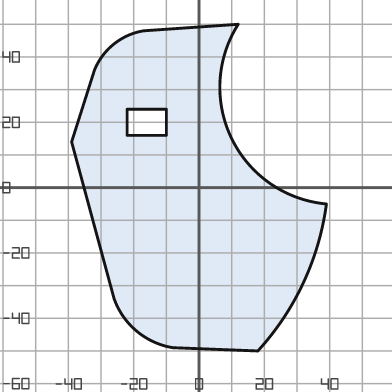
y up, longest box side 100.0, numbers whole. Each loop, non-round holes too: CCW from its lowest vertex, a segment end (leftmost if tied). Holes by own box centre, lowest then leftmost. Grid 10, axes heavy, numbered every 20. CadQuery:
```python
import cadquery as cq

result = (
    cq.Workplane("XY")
    .moveTo(18.0, -50.0)
    .threePointArc((32.0, -29.0), (39.0, -5.0))
    .threePointArc((10.0, 15.0), (12.0, 50.0))
    .lineTo(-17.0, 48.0)
    .threePointArc((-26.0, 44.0), (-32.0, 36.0))
    .lineTo(-39.0, 14.0)
    .lineTo(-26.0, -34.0)
    .threePointArc((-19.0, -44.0), (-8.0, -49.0))
    .close()
    .moveTo(-22.0, 16.0)
    .lineTo(-10.0, 16.0)
    .lineTo(-10.0, 24.0)
    .lineTo(-22.0, 24.0)
    .close()
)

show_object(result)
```